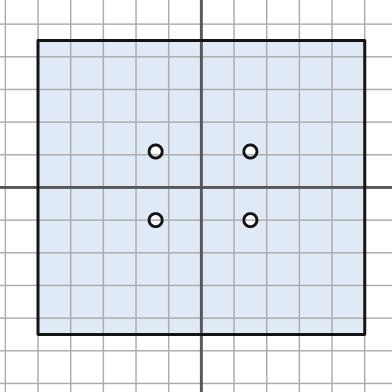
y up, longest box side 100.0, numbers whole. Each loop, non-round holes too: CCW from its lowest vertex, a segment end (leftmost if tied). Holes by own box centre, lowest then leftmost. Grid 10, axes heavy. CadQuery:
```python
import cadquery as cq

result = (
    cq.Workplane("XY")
    .moveTo(-50.0, -45.0)
    .lineTo(50.0, -45.0)
    .lineTo(50.0, 45.0)
    .lineTo(-50.0, 45.0)
    .close()
    .moveTo(-14.0, -10.0)
    .circle(2.0)
    .moveTo(15.0, -10.0)
    .circle(2.0)
    .moveTo(-14.0, 11.0)
    .circle(2.0)
    .moveTo(15.0, 11.0)
    .circle(2.0)
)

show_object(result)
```